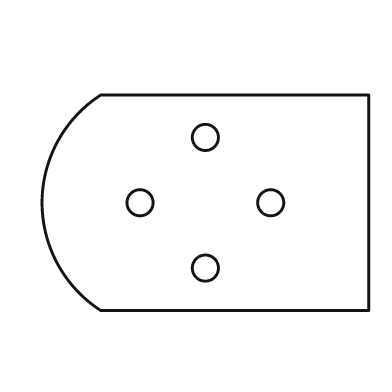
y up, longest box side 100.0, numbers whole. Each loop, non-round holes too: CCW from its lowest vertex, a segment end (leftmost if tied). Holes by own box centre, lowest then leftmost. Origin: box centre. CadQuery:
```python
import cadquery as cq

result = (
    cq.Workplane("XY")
    .moveTo(-32.0, -33.0)
    .lineTo(50.0, -33.0)
    .lineTo(50.0, 33.0)
    .lineTo(-32.0, 33.0)
    .threePointArc((-50.0, 0.0), (-32.0, -33.0))
    .close()
    .moveTo(0.0, -20.0)
    .circle(4.0)
    .moveTo(-20.0, 0.0)
    .circle(4.0)
    .moveTo(20.0, 0.0)
    .circle(4.0)
    .moveTo(0.0, 20.0)
    .circle(4.0)
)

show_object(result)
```